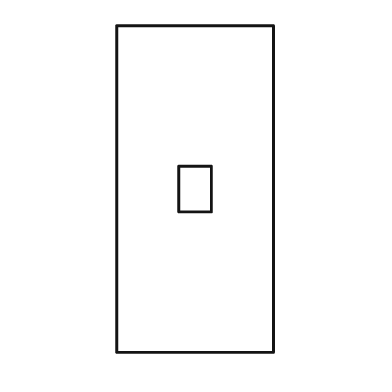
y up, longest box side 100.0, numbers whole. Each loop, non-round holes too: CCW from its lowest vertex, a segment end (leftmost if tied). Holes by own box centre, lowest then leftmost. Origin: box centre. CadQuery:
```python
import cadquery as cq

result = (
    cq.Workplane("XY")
    .moveTo(-24.0, -50.0)
    .lineTo(24.0, -50.0)
    .lineTo(24.0, 50.0)
    .lineTo(-24.0, 50.0)
    .close()
    .moveTo(-5.0, -7.0)
    .lineTo(5.0, -7.0)
    .lineTo(5.0, 7.0)
    .lineTo(-5.0, 7.0)
    .close()
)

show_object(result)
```